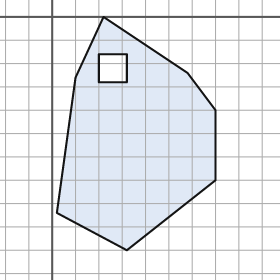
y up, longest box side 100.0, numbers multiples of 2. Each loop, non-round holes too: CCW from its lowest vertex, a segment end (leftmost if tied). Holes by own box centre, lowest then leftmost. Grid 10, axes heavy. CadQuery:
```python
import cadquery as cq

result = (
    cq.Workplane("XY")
    .moveTo(32.0, -100.0)
    .lineTo(70.0, -70.0)
    .lineTo(70.0, -40.0)
    .lineTo(58.0, -24.0)
    .lineTo(22.0, 0.0)
    .lineTo(10.0, -26.0)
    .lineTo(2.0, -84.0)
    .close()
    .moveTo(20.0, -28.0)
    .lineTo(32.0, -28.0)
    .lineTo(32.0, -16.0)
    .lineTo(20.0, -16.0)
    .close()
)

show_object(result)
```